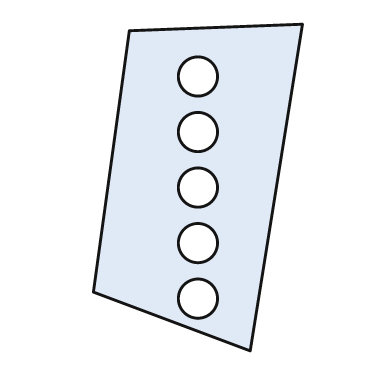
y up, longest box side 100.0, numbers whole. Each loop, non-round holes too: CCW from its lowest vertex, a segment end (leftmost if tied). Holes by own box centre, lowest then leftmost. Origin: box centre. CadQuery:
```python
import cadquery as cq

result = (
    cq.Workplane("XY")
    .moveTo(16.0, -50.0)
    .lineTo(32.0, 50.0)
    .lineTo(-21.0, 48.0)
    .lineTo(-32.0, -32.0)
    .close()
    .moveTo(0.0, -34.0)
    .circle(6.0)
    .moveTo(0.0, -17.0)
    .circle(6.0)
    .moveTo(0.0, 0.0)
    .circle(6.0)
    .moveTo(0.0, 17.0)
    .circle(6.0)
    .moveTo(0.0, 34.0)
    .circle(6.0)
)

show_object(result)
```